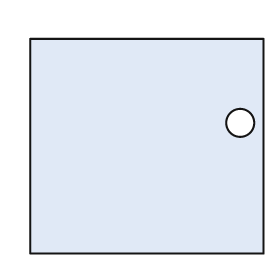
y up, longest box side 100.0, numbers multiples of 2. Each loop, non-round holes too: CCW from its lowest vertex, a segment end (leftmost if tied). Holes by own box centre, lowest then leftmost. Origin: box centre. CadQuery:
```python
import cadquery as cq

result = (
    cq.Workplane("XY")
    .moveTo(-50.0, -46.0)
    .lineTo(50.0, -46.0)
    .lineTo(50.0, 46.0)
    .lineTo(-50.0, 46.0)
    .close()
    .moveTo(40.0, 10.0)
    .circle(6.0)
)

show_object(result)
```